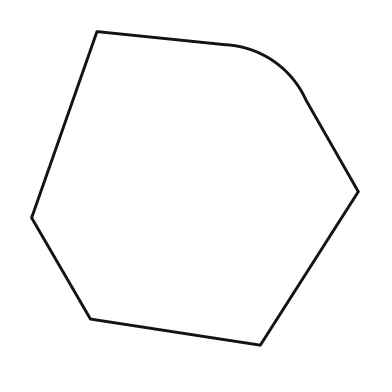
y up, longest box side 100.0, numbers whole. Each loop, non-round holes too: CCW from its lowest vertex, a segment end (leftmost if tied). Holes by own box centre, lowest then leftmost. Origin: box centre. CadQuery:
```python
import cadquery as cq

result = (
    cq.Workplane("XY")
    .moveTo(20.0, -48.0)
    .lineTo(50.0, -1.0)
    .lineTo(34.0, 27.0)
    .threePointArc((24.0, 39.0), (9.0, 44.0))
    .lineTo(-30.0, 48.0)
    .lineTo(-50.0, -9.0)
    .lineTo(-32.0, -40.0)
    .close()
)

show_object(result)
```